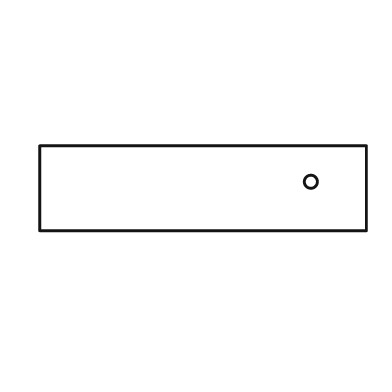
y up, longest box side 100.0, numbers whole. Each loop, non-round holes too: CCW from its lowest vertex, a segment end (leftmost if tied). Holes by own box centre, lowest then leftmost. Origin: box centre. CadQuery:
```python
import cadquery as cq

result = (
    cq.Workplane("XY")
    .moveTo(-50.0, -13.0)
    .lineTo(50.0, -13.0)
    .lineTo(50.0, 13.0)
    .lineTo(-50.0, 13.0)
    .close()
    .moveTo(33.0, 2.0)
    .circle(2.0)
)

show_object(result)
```